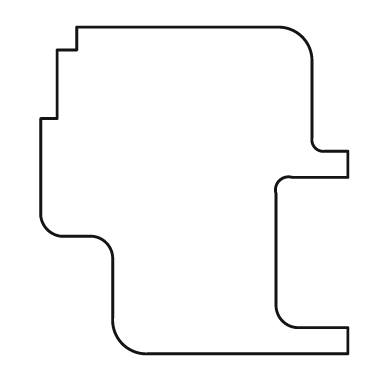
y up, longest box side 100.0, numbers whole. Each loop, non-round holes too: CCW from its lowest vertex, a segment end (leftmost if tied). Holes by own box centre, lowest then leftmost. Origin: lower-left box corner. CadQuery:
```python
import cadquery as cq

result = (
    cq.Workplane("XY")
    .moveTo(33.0, 0.0)
    .lineTo(94.0, 0.0)
    .lineTo(94.0, 8.0)
    .lineTo(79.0, 8.0)
    .threePointArc((74.0, 10.0), (72.0, 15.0))
    .lineTo(72.0, 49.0)
    .threePointArc((73.0, 53.0), (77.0, 54.0))
    .lineTo(94.0, 54.0)
    .lineTo(94.0, 62.0)
    .lineTo(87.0, 62.0)
    .threePointArc((84.0, 63.0), (83.0, 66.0))
    .lineTo(83.0, 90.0)
    .threePointArc((80.0, 97.0), (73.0, 100.0))
    .lineTo(11.0, 100.0)
    .lineTo(11.0, 93.0)
    .lineTo(5.0, 93.0)
    .lineTo(5.0, 72.0)
    .lineTo(0.0, 72.0)
    .lineTo(0.0, 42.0)
    .threePointArc((2.0, 38.0), (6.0, 36.0))
    .lineTo(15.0, 36.0)
    .threePointArc((20.0, 34.0), (22.0, 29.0))
    .lineTo(22.0, 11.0)
    .threePointArc((25.0, 3.0), (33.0, 0.0))
    .close()
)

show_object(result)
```